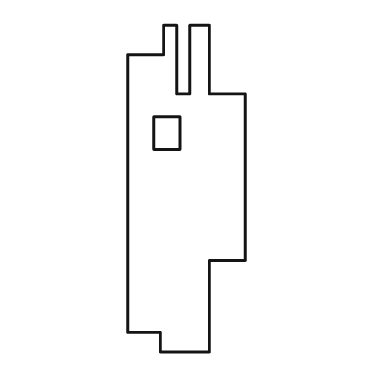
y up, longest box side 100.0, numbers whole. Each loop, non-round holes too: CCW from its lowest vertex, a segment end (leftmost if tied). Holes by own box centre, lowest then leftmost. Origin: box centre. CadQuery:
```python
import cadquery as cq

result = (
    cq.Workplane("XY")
    .moveTo(-8.0, -50.0)
    .lineTo(7.0, -50.0)
    .lineTo(7.0, -22.0)
    .lineTo(18.0, -22.0)
    .lineTo(18.0, 29.0)
    .lineTo(7.0, 29.0)
    .lineTo(7.0, 50.0)
    .lineTo(1.0, 50.0)
    .lineTo(1.0, 29.0)
    .lineTo(-3.0, 29.0)
    .lineTo(-3.0, 50.0)
    .lineTo(-7.0, 50.0)
    .lineTo(-7.0, 41.0)
    .lineTo(-18.0, 41.0)
    .lineTo(-18.0, -44.0)
    .lineTo(-8.0, -44.0)
    .close()
    .moveTo(-10.0, 12.0)
    .lineTo(-2.0, 12.0)
    .lineTo(-2.0, 22.0)
    .lineTo(-10.0, 22.0)
    .close()
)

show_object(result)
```